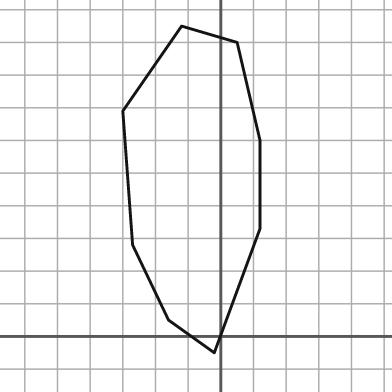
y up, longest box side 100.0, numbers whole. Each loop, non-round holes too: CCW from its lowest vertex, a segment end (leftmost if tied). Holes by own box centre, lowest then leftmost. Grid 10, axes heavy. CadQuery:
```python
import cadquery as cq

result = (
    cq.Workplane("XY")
    .moveTo(-2.0, -5.0)
    .lineTo(12.0, 33.0)
    .lineTo(12.0, 60.0)
    .lineTo(5.0, 90.0)
    .lineTo(-12.0, 95.0)
    .lineTo(-30.0, 69.0)
    .lineTo(-27.0, 28.0)
    .lineTo(-16.0, 5.0)
    .close()
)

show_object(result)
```